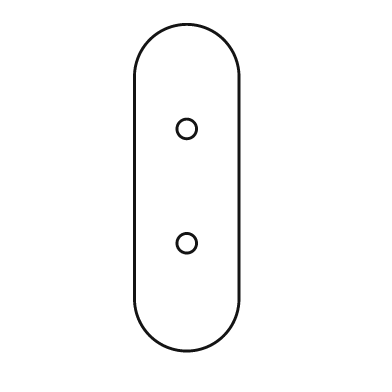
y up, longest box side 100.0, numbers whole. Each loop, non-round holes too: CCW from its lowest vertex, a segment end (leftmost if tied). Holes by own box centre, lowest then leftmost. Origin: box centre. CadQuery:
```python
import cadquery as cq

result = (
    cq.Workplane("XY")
    .moveTo(-16.0, -34.0)
    .threePointArc((0.0, -50.0), (16.0, -34.0))
    .lineTo(16.0, 34.0)
    .threePointArc((0.0, 50.0), (-16.0, 34.0))
    .close()
    .moveTo(0.0, -17.0)
    .circle(3.0)
    .moveTo(0.0, 18.0)
    .circle(3.0)
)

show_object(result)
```